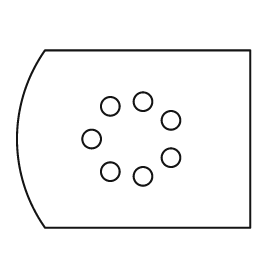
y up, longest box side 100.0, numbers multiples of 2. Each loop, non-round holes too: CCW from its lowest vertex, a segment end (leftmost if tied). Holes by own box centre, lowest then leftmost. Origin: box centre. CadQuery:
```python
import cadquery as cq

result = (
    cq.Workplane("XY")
    .moveTo(-38.0, -38.0)
    .lineTo(50.0, -38.0)
    .lineTo(50.0, 38.0)
    .lineTo(-38.0, 38.0)
    .threePointArc((-50.0, 0.0), (-38.0, -38.0))
    .close()
    .moveTo(4.0, -16.0)
    .circle(4.0)
    .moveTo(-10.0, -14.0)
    .circle(4.0)
    .moveTo(16.0, -8.0)
    .circle(4.0)
    .moveTo(-18.0, 0.0)
    .circle(4.0)
    .moveTo(16.0, 8.0)
    .circle(4.0)
    .moveTo(-10.0, 14.0)
    .circle(4.0)
    .moveTo(4.0, 16.0)
    .circle(4.0)
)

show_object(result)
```